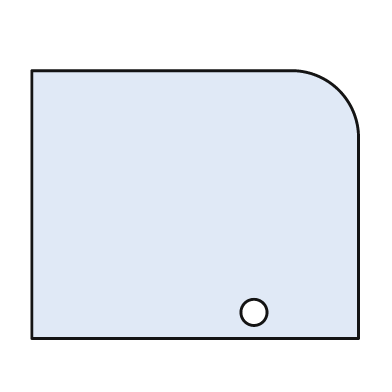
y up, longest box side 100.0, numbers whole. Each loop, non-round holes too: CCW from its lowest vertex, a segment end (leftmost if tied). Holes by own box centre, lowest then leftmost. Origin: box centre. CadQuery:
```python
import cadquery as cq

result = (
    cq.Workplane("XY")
    .moveTo(-50.0, -41.0)
    .lineTo(50.0, -41.0)
    .lineTo(50.0, 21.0)
    .threePointArc((44.0, 35.0), (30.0, 41.0))
    .lineTo(-50.0, 41.0)
    .close()
    .moveTo(18.0, -33.0)
    .circle(4.0)
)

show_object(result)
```